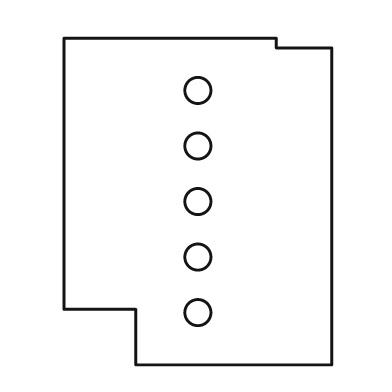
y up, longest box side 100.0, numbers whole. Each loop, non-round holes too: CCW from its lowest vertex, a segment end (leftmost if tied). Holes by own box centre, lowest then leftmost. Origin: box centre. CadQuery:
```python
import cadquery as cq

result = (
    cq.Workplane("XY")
    .moveTo(-19.0, -50.0)
    .lineTo(41.0, -50.0)
    .lineTo(41.0, 47.0)
    .lineTo(24.0, 47.0)
    .lineTo(24.0, 50.0)
    .lineTo(-41.0, 50.0)
    .lineTo(-41.0, -33.0)
    .lineTo(-19.0, -33.0)
    .close()
    .moveTo(0.0, -34.0)
    .circle(4.0)
    .moveTo(0.0, -17.0)
    .circle(4.0)
    .moveTo(0.0, 0.0)
    .circle(4.0)
    .moveTo(0.0, 17.0)
    .circle(4.0)
    .moveTo(0.0, 34.0)
    .circle(4.0)
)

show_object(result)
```